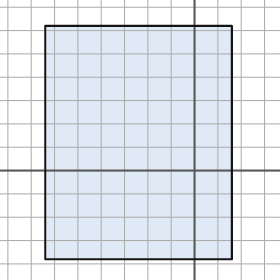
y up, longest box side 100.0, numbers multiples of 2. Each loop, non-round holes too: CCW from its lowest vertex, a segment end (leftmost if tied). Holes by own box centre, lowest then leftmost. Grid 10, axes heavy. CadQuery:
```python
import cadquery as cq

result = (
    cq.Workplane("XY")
    .moveTo(-64.0, -38.0)
    .lineTo(16.0, -38.0)
    .lineTo(16.0, 62.0)
    .lineTo(-64.0, 62.0)
    .close()
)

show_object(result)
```